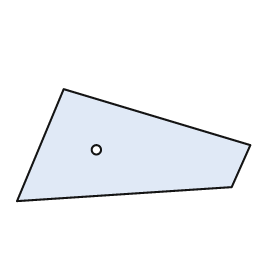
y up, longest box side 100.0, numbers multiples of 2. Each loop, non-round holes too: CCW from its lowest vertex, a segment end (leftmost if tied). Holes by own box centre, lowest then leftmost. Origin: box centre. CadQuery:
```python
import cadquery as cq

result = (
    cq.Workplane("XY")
    .moveTo(-50.0, -24.0)
    .lineTo(42.0, -18.0)
    .lineTo(50.0, 0.0)
    .lineTo(-30.0, 24.0)
    .close()
    .moveTo(-16.0, -2.0)
    .circle(2.0)
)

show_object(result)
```